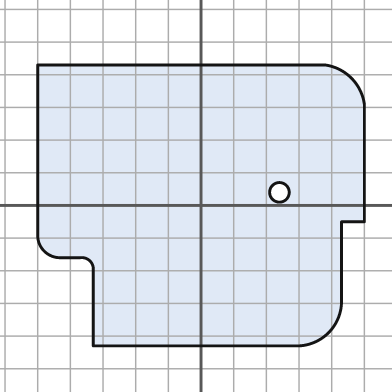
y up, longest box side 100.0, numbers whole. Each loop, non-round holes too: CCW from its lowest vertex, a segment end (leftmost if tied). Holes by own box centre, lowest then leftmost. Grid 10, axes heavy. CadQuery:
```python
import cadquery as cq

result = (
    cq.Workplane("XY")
    .moveTo(-33.0, -43.0)
    .lineTo(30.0, -43.0)
    .threePointArc((39.0, -39.0), (43.0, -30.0))
    .lineTo(43.0, -5.0)
    .lineTo(50.0, -5.0)
    .lineTo(50.0, 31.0)
    .threePointArc((46.0, 39.0), (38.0, 43.0))
    .lineTo(-50.0, 43.0)
    .lineTo(-50.0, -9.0)
    .threePointArc((-48.0, -14.0), (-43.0, -16.0))
    .lineTo(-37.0, -16.0)
    .threePointArc((-34.0, -17.0), (-33.0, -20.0))
    .close()
    .moveTo(24.0, 4.0)
    .circle(3.0)
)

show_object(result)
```